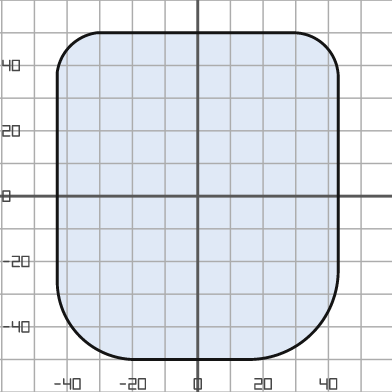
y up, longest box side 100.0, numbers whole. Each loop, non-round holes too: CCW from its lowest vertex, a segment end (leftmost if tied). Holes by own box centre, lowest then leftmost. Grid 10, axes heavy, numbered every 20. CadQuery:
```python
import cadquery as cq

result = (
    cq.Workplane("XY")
    .moveTo(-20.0, -50.0)
    .lineTo(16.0, -50.0)
    .threePointArc((35.0, -42.0), (43.0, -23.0))
    .lineTo(43.0, 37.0)
    .threePointArc((39.0, 46.0), (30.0, 50.0))
    .lineTo(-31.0, 50.0)
    .threePointArc((-39.0, 46.0), (-43.0, 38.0))
    .lineTo(-43.0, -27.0)
    .threePointArc((-36.0, -43.0), (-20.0, -50.0))
    .close()
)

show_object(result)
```